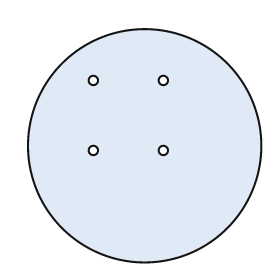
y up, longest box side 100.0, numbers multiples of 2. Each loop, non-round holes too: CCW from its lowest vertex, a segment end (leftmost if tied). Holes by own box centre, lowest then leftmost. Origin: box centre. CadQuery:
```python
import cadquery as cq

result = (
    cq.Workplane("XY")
    .moveTo(0.0, 0.0)
    .circle(50.0)
    .moveTo(-22.0, -2.0)
    .circle(2.0)
    .moveTo(8.0, -2.0)
    .circle(2.0)
    .moveTo(-22.0, 28.0)
    .circle(2.0)
    .moveTo(8.0, 28.0)
    .circle(2.0)
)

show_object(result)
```